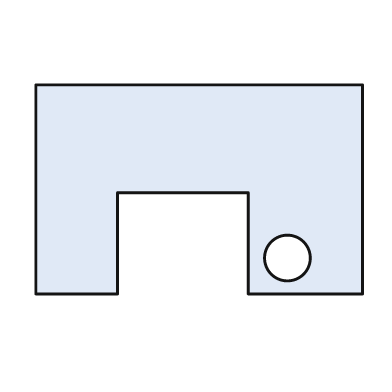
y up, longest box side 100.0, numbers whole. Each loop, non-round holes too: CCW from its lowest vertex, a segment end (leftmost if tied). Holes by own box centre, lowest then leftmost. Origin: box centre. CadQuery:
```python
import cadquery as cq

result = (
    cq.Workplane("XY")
    .moveTo(-50.0, -32.0)
    .lineTo(-25.0, -32.0)
    .lineTo(-25.0, -1.0)
    .lineTo(15.0, -1.0)
    .lineTo(15.0, -32.0)
    .lineTo(50.0, -32.0)
    .lineTo(50.0, 32.0)
    .lineTo(-50.0, 32.0)
    .close()
    .moveTo(27.0, -21.0)
    .circle(7.0)
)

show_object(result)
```